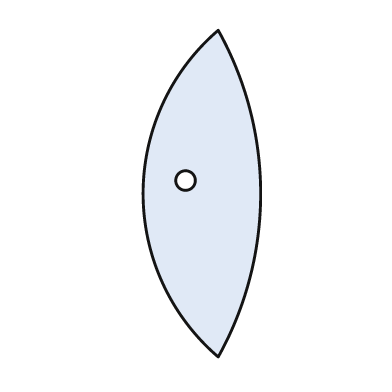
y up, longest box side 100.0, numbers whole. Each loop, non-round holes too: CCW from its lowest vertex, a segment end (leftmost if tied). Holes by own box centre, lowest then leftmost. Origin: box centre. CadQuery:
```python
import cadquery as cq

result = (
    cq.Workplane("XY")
    .moveTo(5.0, -50.0)
    .threePointArc((18.0, 0.0), (5.0, 50.0))
    .threePointArc((-18.0, 0.0), (5.0, -50.0))
    .close()
    .moveTo(-5.0, 4.0)
    .circle(3.0)
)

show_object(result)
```